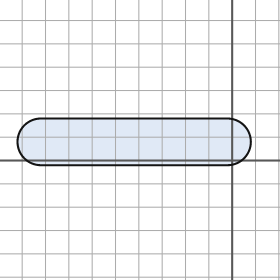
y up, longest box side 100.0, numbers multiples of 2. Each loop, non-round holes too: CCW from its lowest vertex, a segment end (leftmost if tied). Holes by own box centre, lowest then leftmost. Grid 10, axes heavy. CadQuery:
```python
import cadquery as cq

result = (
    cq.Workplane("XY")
    .moveTo(-82.0, -2.0)
    .lineTo(-2.0, -2.0)
    .threePointArc((8.0, 8.0), (-2.0, 18.0))
    .lineTo(-82.0, 18.0)
    .threePointArc((-92.0, 8.0), (-82.0, -2.0))
    .close()
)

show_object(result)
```